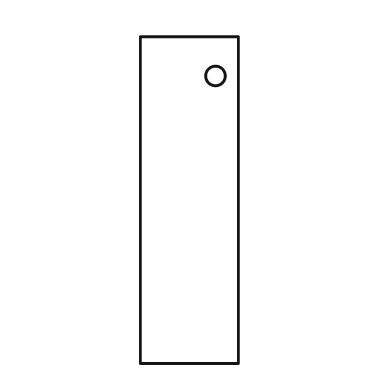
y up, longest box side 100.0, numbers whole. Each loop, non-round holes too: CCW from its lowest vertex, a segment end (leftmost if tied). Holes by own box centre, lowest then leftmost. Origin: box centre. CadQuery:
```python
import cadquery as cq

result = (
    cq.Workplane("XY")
    .moveTo(-15.0, -50.0)
    .lineTo(15.0, -50.0)
    .lineTo(15.0, 50.0)
    .lineTo(-15.0, 50.0)
    .close()
    .moveTo(8.0, 38.0)
    .circle(3.0)
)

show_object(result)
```